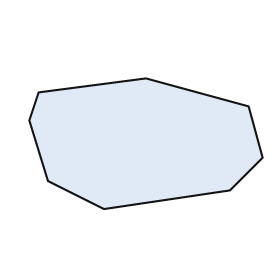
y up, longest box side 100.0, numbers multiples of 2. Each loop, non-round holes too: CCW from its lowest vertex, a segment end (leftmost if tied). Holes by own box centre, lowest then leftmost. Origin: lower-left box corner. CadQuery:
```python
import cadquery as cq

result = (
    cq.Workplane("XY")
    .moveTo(32.0, 0.0)
    .lineTo(86.0, 8.0)
    .lineTo(100.0, 22.0)
    .lineTo(94.0, 44.0)
    .lineTo(50.0, 56.0)
    .lineTo(4.0, 50.0)
    .lineTo(0.0, 38.0)
    .lineTo(8.0, 12.0)
    .close()
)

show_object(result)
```